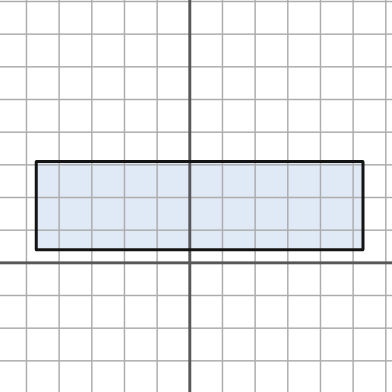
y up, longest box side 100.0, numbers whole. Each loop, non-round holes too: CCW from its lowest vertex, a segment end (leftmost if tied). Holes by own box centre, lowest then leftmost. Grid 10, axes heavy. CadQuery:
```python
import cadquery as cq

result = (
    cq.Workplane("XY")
    .moveTo(-47.0, 4.0)
    .lineTo(53.0, 4.0)
    .lineTo(53.0, 31.0)
    .lineTo(-47.0, 31.0)
    .close()
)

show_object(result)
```